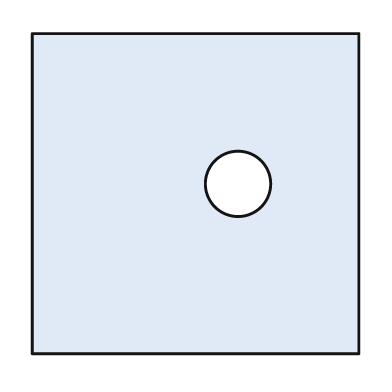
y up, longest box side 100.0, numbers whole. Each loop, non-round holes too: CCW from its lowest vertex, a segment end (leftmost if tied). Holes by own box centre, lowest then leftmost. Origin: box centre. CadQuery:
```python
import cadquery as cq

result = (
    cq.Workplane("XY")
    .moveTo(-50.0, -49.0)
    .lineTo(50.0, -49.0)
    .lineTo(50.0, 49.0)
    .lineTo(-50.0, 49.0)
    .close()
    .moveTo(13.0, 3.0)
    .circle(10.0)
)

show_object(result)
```